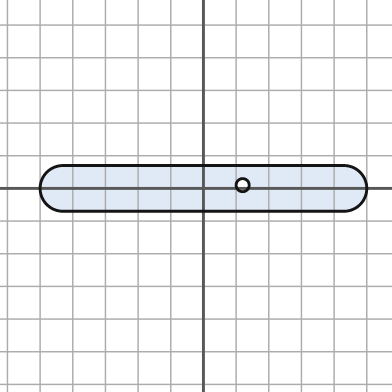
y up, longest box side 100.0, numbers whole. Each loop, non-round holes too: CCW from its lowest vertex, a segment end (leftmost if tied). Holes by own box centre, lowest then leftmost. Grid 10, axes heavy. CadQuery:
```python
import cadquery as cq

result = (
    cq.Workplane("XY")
    .moveTo(-43.0, -7.0)
    .lineTo(43.0, -7.0)
    .threePointArc((50.0, 0.0), (43.0, 7.0))
    .lineTo(-43.0, 7.0)
    .threePointArc((-50.0, 0.0), (-43.0, -7.0))
    .close()
    .moveTo(12.0, 1.0)
    .circle(2.0)
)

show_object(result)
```